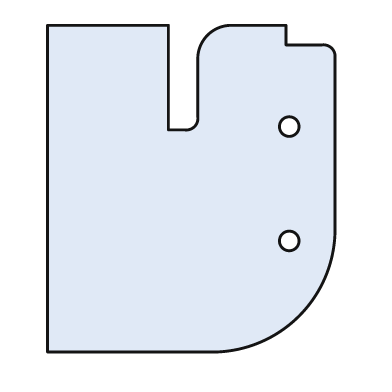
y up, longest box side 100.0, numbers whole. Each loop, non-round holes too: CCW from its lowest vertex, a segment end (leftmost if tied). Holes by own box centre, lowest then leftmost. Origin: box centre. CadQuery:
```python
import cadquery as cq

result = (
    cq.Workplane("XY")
    .moveTo(-44.0, -50.0)
    .lineTo(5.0, -50.0)
    .threePointArc((33.0, -39.0), (44.0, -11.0))
    .lineTo(44.0, 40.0)
    .threePointArc((43.0, 43.0), (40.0, 44.0))
    .lineTo(29.0, 44.0)
    .lineTo(29.0, 50.0)
    .lineTo(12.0, 50.0)
    .threePointArc((5.0, 47.0), (2.0, 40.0))
    .lineTo(2.0, 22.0)
    .threePointArc((1.0, 19.0), (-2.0, 18.0))
    .lineTo(-7.0, 18.0)
    .lineTo(-7.0, 50.0)
    .lineTo(-44.0, 50.0)
    .close()
    .moveTo(30.0, -16.0)
    .circle(3.0)
    .moveTo(30.0, 19.0)
    .circle(3.0)
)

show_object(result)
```